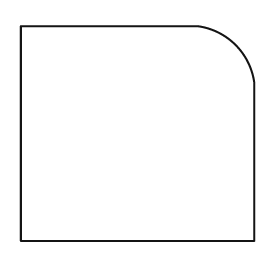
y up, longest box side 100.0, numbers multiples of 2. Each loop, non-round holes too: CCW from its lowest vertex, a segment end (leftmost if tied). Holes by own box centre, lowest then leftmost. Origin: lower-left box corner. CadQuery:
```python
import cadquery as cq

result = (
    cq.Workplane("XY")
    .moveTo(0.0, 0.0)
    .lineTo(100.0, 0.0)
    .lineTo(100.0, 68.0)
    .threePointArc((92.0, 84.0), (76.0, 92.0))
    .lineTo(0.0, 92.0)
    .close()
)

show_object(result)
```